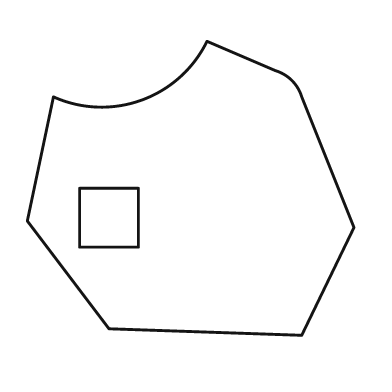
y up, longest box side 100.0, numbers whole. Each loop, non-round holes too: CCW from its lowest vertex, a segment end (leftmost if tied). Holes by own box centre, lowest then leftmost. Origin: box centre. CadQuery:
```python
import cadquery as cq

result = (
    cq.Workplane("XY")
    .moveTo(34.0, -45.0)
    .lineTo(50.0, -12.0)
    .lineTo(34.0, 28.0)
    .threePointArc((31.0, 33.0), (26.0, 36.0))
    .lineTo(5.0, 45.0)
    .threePointArc((-15.0, 27.0), (-42.0, 28.0))
    .lineTo(-50.0, -10.0)
    .lineTo(-25.0, -43.0)
    .close()
    .moveTo(-34.0, -18.0)
    .lineTo(-16.0, -18.0)
    .lineTo(-16.0, 0.0)
    .lineTo(-34.0, 0.0)
    .close()
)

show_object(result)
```